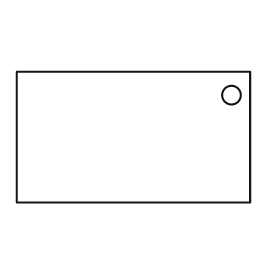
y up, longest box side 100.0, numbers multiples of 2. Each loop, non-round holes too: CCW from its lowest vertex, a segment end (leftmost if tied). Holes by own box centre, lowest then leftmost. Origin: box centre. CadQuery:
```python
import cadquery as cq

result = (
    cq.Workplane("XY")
    .moveTo(-50.0, -28.0)
    .lineTo(50.0, -28.0)
    .lineTo(50.0, 28.0)
    .lineTo(-50.0, 28.0)
    .close()
    .moveTo(42.0, 18.0)
    .circle(4.0)
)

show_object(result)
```